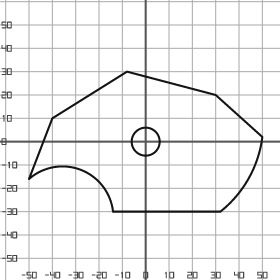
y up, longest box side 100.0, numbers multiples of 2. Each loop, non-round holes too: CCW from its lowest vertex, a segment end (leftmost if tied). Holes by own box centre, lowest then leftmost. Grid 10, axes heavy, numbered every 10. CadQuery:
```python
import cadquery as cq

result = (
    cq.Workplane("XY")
    .moveTo(-14.0, -30.0)
    .lineTo(32.0, -30.0)
    .threePointArc((44.0, -16.0), (50.0, 2.0))
    .lineTo(30.0, 20.0)
    .lineTo(-8.0, 30.0)
    .lineTo(-40.0, 10.0)
    .lineTo(-50.0, -16.0)
    .threePointArc((-28.0, -12.0), (-14.0, -30.0))
    .close()
    .moveTo(0.0, 0.0)
    .circle(6.0)
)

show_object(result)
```